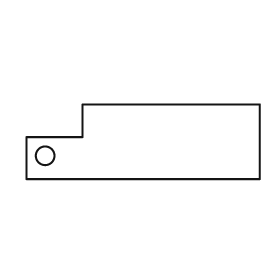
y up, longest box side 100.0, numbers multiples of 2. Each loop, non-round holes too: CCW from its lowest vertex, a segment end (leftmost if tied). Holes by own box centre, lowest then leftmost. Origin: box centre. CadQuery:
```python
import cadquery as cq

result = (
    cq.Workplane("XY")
    .moveTo(-50.0, -16.0)
    .lineTo(50.0, -16.0)
    .lineTo(50.0, 16.0)
    .lineTo(-26.0, 16.0)
    .lineTo(-26.0, 2.0)
    .lineTo(-50.0, 2.0)
    .close()
    .moveTo(-42.0, -6.0)
    .circle(4.0)
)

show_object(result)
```